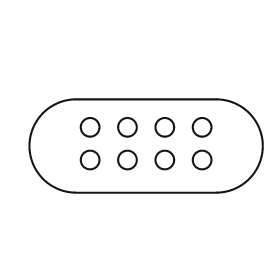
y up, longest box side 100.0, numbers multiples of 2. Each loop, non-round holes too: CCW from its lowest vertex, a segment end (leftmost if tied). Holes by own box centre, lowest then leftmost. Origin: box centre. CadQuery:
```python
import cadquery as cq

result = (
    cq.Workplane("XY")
    .moveTo(-30.0, -20.0)
    .lineTo(30.0, -20.0)
    .threePointArc((50.0, 0.0), (30.0, 20.0))
    .lineTo(-30.0, 20.0)
    .threePointArc((-50.0, 0.0), (-30.0, -20.0))
    .close()
    .moveTo(-24.0, -6.0)
    .circle(4.0)
    .moveTo(-8.0, -6.0)
    .circle(4.0)
    .moveTo(8.0, -6.0)
    .circle(4.0)
    .moveTo(24.0, -6.0)
    .circle(4.0)
    .moveTo(-24.0, 8.0)
    .circle(4.0)
    .moveTo(-8.0, 8.0)
    .circle(4.0)
    .moveTo(8.0, 8.0)
    .circle(4.0)
    .moveTo(24.0, 8.0)
    .circle(4.0)
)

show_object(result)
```